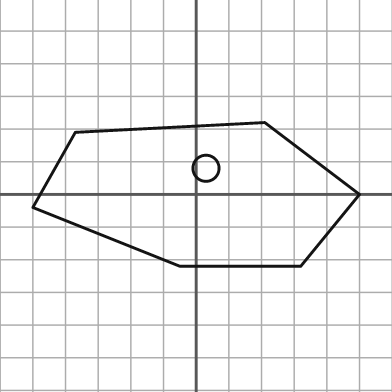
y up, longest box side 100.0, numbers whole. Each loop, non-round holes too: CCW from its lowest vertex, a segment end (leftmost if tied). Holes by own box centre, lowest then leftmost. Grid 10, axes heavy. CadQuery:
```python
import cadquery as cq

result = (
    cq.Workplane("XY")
    .moveTo(-5.0, -22.0)
    .lineTo(32.0, -22.0)
    .lineTo(50.0, 0.0)
    .lineTo(21.0, 22.0)
    .lineTo(-37.0, 19.0)
    .lineTo(-50.0, -4.0)
    .close()
    .moveTo(3.0, 8.0)
    .circle(4.0)
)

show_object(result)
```